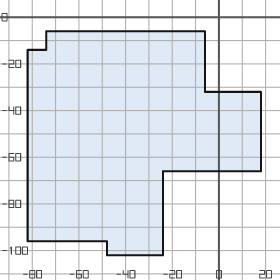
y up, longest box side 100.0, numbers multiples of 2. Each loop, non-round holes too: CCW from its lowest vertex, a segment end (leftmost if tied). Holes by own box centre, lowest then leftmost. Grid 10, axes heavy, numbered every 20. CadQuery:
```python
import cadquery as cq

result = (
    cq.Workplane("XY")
    .moveTo(-48.0, -102.0)
    .lineTo(-24.0, -102.0)
    .lineTo(-24.0, -66.0)
    .lineTo(18.0, -66.0)
    .lineTo(18.0, -32.0)
    .lineTo(-6.0, -32.0)
    .lineTo(-6.0, -6.0)
    .lineTo(-74.0, -6.0)
    .lineTo(-74.0, -14.0)
    .lineTo(-82.0, -14.0)
    .lineTo(-82.0, -96.0)
    .lineTo(-48.0, -96.0)
    .close()
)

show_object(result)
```